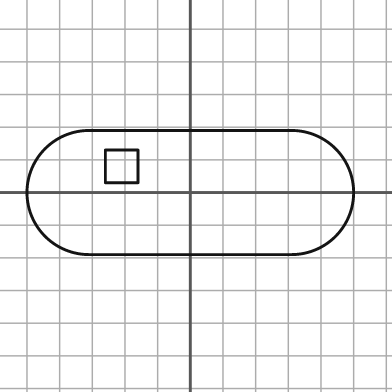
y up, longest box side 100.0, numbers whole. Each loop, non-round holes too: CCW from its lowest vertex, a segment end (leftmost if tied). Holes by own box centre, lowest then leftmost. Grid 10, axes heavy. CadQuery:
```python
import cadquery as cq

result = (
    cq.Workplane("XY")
    .moveTo(-31.0, -19.0)
    .lineTo(31.0, -19.0)
    .threePointArc((50.0, 0.0), (31.0, 19.0))
    .lineTo(-31.0, 19.0)
    .threePointArc((-50.0, 0.0), (-31.0, -19.0))
    .close()
    .moveTo(-26.0, 3.0)
    .lineTo(-16.0, 3.0)
    .lineTo(-16.0, 13.0)
    .lineTo(-26.0, 13.0)
    .close()
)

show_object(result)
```